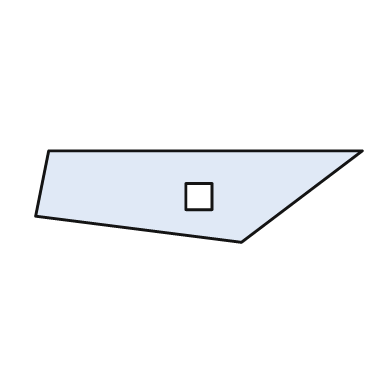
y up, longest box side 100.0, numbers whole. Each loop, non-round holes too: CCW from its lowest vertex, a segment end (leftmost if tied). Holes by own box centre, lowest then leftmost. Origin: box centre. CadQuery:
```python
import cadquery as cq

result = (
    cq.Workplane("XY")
    .moveTo(13.0, -14.0)
    .lineTo(50.0, 14.0)
    .lineTo(-46.0, 14.0)
    .lineTo(-50.0, -6.0)
    .close()
    .moveTo(-4.0, -4.0)
    .lineTo(4.0, -4.0)
    .lineTo(4.0, 4.0)
    .lineTo(-4.0, 4.0)
    .close()
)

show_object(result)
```